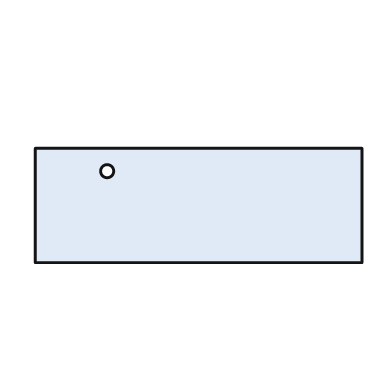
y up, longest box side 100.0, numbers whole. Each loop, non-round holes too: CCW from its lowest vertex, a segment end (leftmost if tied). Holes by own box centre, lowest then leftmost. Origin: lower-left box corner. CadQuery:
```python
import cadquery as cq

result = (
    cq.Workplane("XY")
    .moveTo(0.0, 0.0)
    .lineTo(100.0, 0.0)
    .lineTo(100.0, 35.0)
    .lineTo(0.0, 35.0)
    .close()
    .moveTo(22.0, 28.0)
    .circle(2.0)
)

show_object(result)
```